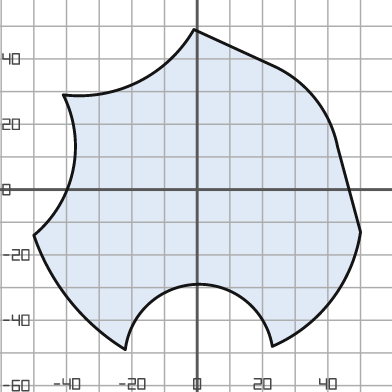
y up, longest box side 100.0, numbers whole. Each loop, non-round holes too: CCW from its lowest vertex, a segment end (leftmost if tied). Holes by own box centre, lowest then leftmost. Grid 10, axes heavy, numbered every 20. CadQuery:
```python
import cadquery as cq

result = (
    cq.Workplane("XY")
    .moveTo(-22.0, -49.0)
    .threePointArc((0.0, -29.0), (23.0, -48.0))
    .threePointArc((41.0, -34.0), (50.0, -13.0))
    .lineTo(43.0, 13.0)
    .threePointArc((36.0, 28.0), (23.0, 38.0))
    .lineTo(-1.0, 49.0)
    .threePointArc((-18.0, 33.0), (-41.0, 29.0))
    .threePointArc((-38.0, 6.0), (-50.0, -14.0))
    .threePointArc((-39.0, -34.0), (-22.0, -49.0))
    .close()
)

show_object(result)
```